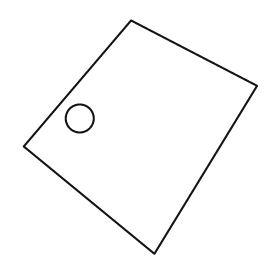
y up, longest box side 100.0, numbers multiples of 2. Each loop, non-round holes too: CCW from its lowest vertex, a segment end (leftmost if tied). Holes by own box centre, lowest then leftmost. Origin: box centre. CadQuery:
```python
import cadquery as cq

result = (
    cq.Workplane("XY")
    .moveTo(6.0, -50.0)
    .lineTo(50.0, 22.0)
    .lineTo(-4.0, 50.0)
    .lineTo(-50.0, -4.0)
    .close()
    .moveTo(-26.0, 8.0)
    .circle(6.0)
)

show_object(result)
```